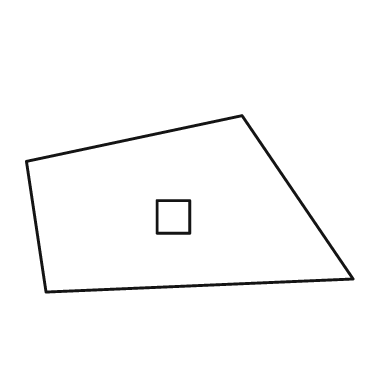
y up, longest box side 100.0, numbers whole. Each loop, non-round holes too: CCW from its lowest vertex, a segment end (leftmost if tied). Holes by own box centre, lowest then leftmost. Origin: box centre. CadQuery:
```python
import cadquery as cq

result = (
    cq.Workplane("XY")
    .moveTo(-44.0, -27.0)
    .lineTo(50.0, -23.0)
    .lineTo(16.0, 27.0)
    .lineTo(-50.0, 13.0)
    .close()
    .moveTo(-10.0, -9.0)
    .lineTo(0.0, -9.0)
    .lineTo(0.0, 1.0)
    .lineTo(-10.0, 1.0)
    .close()
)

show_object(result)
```